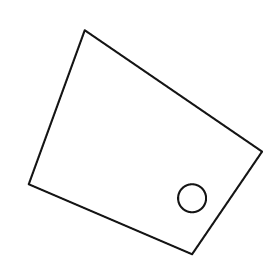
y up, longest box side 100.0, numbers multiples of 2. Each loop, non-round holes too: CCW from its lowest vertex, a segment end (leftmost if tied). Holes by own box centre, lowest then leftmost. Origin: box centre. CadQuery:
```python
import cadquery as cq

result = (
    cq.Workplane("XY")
    .moveTo(20.0, -48.0)
    .lineTo(50.0, -4.0)
    .lineTo(-26.0, 48.0)
    .lineTo(-50.0, -18.0)
    .close()
    .moveTo(20.0, -24.0)
    .circle(6.0)
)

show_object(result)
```